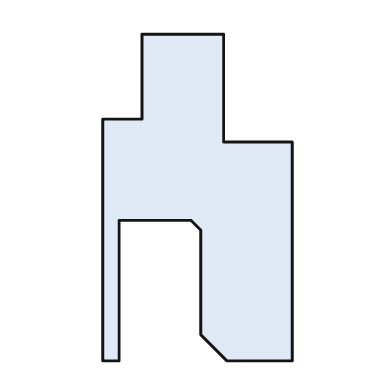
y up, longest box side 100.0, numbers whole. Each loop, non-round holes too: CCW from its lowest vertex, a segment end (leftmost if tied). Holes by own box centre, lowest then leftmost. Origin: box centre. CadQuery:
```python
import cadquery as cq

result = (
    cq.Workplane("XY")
    .moveTo(-29.0, -50.0)
    .lineTo(-24.0, -50.0)
    .lineTo(-24.0, -7.0)
    .lineTo(-2.0, -7.0)
    .lineTo(1.0, -10.0)
    .lineTo(1.0, -42.0)
    .lineTo(9.0, -50.0)
    .lineTo(29.0, -50.0)
    .lineTo(29.0, 17.0)
    .lineTo(8.0, 17.0)
    .lineTo(8.0, 50.0)
    .lineTo(-17.0, 50.0)
    .lineTo(-17.0, 24.0)
    .lineTo(-29.0, 24.0)
    .close()
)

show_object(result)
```